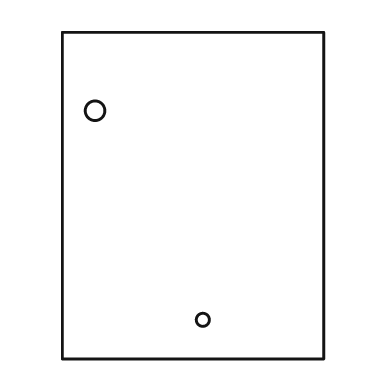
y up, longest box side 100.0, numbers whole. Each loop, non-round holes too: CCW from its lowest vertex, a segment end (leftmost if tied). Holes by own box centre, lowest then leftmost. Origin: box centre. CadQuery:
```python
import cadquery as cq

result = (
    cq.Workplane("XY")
    .moveTo(-40.0, -50.0)
    .lineTo(40.0, -50.0)
    .lineTo(40.0, 50.0)
    .lineTo(-40.0, 50.0)
    .close()
    .moveTo(3.0, -38.0)
    .circle(2.0)
    .moveTo(-30.0, 26.0)
    .circle(3.0)
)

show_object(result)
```